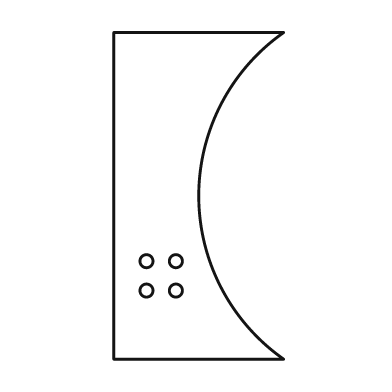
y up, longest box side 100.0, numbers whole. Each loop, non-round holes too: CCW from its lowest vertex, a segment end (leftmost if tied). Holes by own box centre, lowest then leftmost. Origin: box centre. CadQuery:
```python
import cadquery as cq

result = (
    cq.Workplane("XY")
    .moveTo(-26.0, -50.0)
    .lineTo(26.0, -50.0)
    .threePointArc((0.0, 0.0), (26.0, 50.0))
    .lineTo(-26.0, 50.0)
    .close()
    .moveTo(-16.0, -29.0)
    .circle(2.0)
    .moveTo(-7.0, -29.0)
    .circle(2.0)
    .moveTo(-16.0, -20.0)
    .circle(2.0)
    .moveTo(-7.0, -20.0)
    .circle(2.0)
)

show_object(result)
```